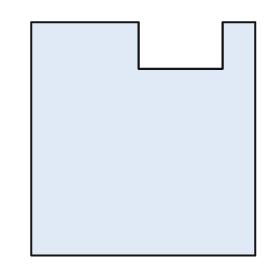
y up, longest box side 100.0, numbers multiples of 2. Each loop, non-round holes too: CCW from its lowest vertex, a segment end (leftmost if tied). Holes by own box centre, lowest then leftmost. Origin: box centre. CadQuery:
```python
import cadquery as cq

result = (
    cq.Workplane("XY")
    .moveTo(-48.0, -50.0)
    .lineTo(48.0, -50.0)
    .lineTo(48.0, 50.0)
    .lineTo(34.0, 50.0)
    .lineTo(34.0, 30.0)
    .lineTo(-2.0, 30.0)
    .lineTo(-2.0, 50.0)
    .lineTo(-48.0, 50.0)
    .close()
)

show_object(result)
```